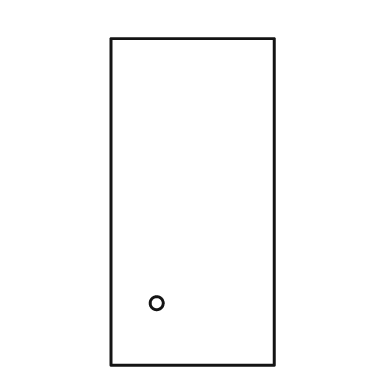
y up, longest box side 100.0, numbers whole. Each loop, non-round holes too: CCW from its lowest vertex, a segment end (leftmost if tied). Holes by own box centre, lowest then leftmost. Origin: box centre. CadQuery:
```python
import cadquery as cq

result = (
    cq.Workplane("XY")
    .moveTo(-25.0, -50.0)
    .lineTo(25.0, -50.0)
    .lineTo(25.0, 50.0)
    .lineTo(-25.0, 50.0)
    .close()
    .moveTo(-11.0, -31.0)
    .circle(2.0)
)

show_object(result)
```